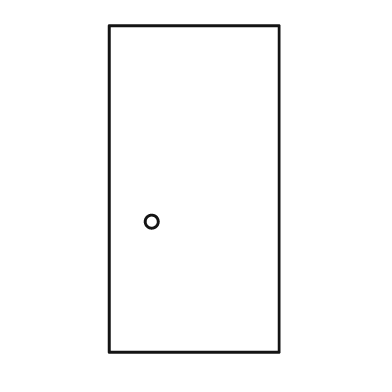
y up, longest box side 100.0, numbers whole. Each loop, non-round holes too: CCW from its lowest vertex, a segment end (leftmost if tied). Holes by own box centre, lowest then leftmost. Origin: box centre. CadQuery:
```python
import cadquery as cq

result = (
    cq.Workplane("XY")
    .moveTo(-26.0, -50.0)
    .lineTo(26.0, -50.0)
    .lineTo(26.0, 50.0)
    .lineTo(-26.0, 50.0)
    .close()
    .moveTo(-13.0, -10.0)
    .circle(2.0)
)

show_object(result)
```